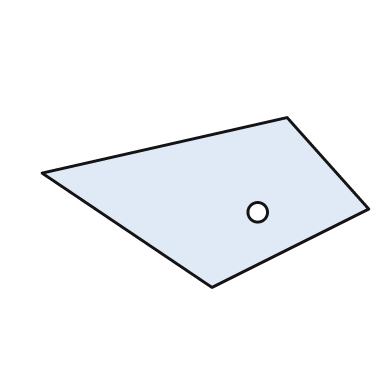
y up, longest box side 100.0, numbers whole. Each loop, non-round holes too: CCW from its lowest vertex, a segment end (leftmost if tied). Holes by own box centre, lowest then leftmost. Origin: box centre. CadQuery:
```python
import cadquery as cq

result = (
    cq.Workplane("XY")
    .moveTo(2.0, -26.0)
    .lineTo(50.0, -2.0)
    .lineTo(25.0, 26.0)
    .lineTo(-50.0, 9.0)
    .close()
    .moveTo(16.0, -3.0)
    .circle(3.0)
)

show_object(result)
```